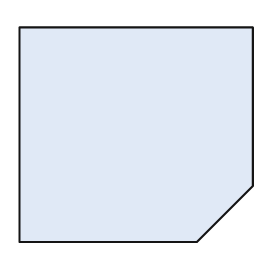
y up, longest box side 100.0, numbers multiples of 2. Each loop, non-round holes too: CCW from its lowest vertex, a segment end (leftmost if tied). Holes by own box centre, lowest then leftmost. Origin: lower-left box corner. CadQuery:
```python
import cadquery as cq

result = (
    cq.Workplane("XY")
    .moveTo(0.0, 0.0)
    .lineTo(76.0, 0.0)
    .lineTo(100.0, 24.0)
    .lineTo(100.0, 92.0)
    .lineTo(0.0, 92.0)
    .close()
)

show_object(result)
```